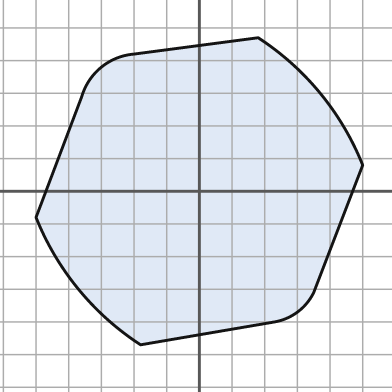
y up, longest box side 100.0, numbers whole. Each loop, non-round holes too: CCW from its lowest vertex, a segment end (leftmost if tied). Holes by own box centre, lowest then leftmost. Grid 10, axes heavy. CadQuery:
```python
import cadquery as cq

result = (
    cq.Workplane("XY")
    .moveTo(-18.0, -47.0)
    .lineTo(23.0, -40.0)
    .threePointArc((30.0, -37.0), (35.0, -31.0))
    .lineTo(50.0, 8.0)
    .threePointArc((37.0, 30.0), (18.0, 47.0))
    .lineTo(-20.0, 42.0)
    .threePointArc((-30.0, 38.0), (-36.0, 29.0))
    .lineTo(-50.0, -8.0)
    .threePointArc((-37.0, -30.0), (-18.0, -47.0))
    .close()
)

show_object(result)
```